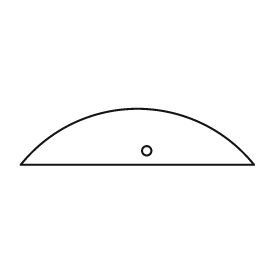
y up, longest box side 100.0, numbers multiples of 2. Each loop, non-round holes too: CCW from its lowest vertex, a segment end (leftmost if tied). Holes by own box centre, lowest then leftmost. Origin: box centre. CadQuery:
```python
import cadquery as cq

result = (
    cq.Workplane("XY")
    .moveTo(-50.0, -12.0)
    .lineTo(50.0, -12.0)
    .threePointArc((0.0, 12.0), (-50.0, -12.0))
    .close()
    .moveTo(4.0, -6.0)
    .circle(2.0)
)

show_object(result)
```